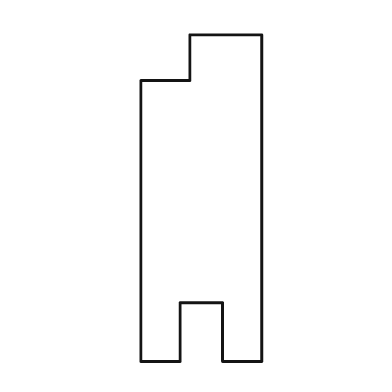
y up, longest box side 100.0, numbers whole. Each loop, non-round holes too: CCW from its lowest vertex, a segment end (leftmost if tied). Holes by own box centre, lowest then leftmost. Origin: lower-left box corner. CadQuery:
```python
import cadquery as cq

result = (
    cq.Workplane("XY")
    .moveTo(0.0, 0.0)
    .lineTo(12.0, 0.0)
    .lineTo(12.0, 18.0)
    .lineTo(25.0, 18.0)
    .lineTo(25.0, 0.0)
    .lineTo(37.0, 0.0)
    .lineTo(37.0, 100.0)
    .lineTo(15.0, 100.0)
    .lineTo(15.0, 86.0)
    .lineTo(0.0, 86.0)
    .close()
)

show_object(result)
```